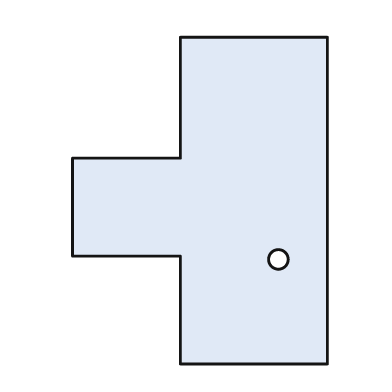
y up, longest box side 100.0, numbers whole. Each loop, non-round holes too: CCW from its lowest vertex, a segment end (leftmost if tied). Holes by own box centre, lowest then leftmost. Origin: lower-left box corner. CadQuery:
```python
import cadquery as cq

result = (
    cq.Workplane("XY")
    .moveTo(33.0, 0.0)
    .lineTo(78.0, 0.0)
    .lineTo(78.0, 100.0)
    .lineTo(33.0, 100.0)
    .lineTo(33.0, 63.0)
    .lineTo(0.0, 63.0)
    .lineTo(0.0, 33.0)
    .lineTo(33.0, 33.0)
    .close()
    .moveTo(63.0, 32.0)
    .circle(3.0)
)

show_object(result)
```